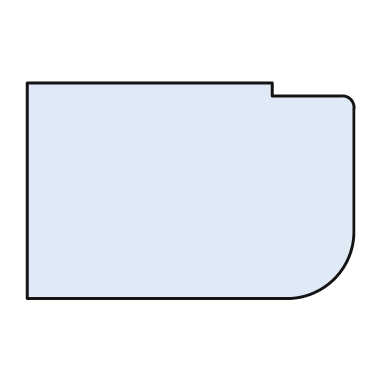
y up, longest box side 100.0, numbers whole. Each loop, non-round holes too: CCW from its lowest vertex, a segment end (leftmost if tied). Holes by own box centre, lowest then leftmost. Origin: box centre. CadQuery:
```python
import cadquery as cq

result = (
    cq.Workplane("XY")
    .moveTo(-50.0, -33.0)
    .lineTo(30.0, -33.0)
    .threePointArc((44.0, -27.0), (50.0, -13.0))
    .lineTo(50.0, 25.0)
    .threePointArc((49.0, 28.0), (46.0, 29.0))
    .lineTo(25.0, 29.0)
    .lineTo(25.0, 33.0)
    .lineTo(-50.0, 33.0)
    .close()
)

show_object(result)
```